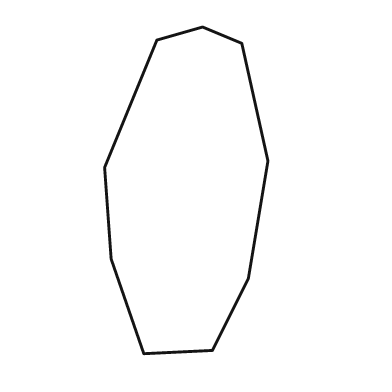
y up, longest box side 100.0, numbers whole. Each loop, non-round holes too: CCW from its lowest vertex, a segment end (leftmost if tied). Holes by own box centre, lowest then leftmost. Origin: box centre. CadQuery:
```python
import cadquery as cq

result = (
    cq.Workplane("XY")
    .moveTo(-13.0, -50.0)
    .lineTo(8.0, -49.0)
    .lineTo(19.0, -27.0)
    .lineTo(25.0, 9.0)
    .lineTo(17.0, 45.0)
    .lineTo(5.0, 50.0)
    .lineTo(-9.0, 46.0)
    .lineTo(-25.0, 7.0)
    .lineTo(-23.0, -21.0)
    .close()
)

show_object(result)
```